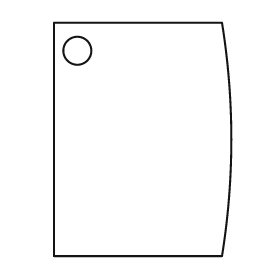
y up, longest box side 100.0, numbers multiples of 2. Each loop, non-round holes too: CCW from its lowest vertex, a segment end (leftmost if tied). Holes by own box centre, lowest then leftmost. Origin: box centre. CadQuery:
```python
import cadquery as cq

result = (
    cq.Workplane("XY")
    .moveTo(-38.0, -50.0)
    .lineTo(34.0, -50.0)
    .threePointArc((38.0, 0.0), (34.0, 50.0))
    .lineTo(-38.0, 50.0)
    .close()
    .moveTo(-28.0, 38.0)
    .circle(6.0)
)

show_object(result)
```